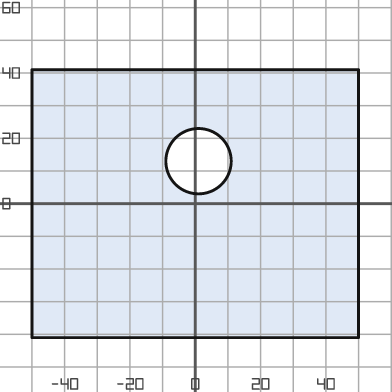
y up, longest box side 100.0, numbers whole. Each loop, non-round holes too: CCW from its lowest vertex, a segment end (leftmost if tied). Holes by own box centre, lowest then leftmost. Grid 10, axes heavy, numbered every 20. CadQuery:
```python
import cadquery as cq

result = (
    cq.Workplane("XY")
    .moveTo(-50.0, -41.0)
    .lineTo(50.0, -41.0)
    .lineTo(50.0, 41.0)
    .lineTo(-50.0, 41.0)
    .close()
    .moveTo(1.0, 13.0)
    .circle(10.0)
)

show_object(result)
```